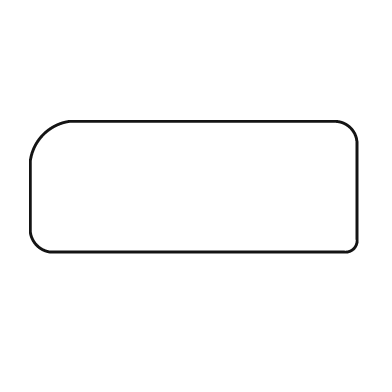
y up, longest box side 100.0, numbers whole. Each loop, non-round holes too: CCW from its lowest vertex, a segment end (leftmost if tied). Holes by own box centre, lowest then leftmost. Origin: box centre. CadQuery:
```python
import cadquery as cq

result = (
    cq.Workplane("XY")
    .moveTo(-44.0, -20.0)
    .lineTo(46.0, -20.0)
    .threePointArc((49.0, -19.0), (50.0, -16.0))
    .lineTo(50.0, 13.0)
    .threePointArc((48.0, 18.0), (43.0, 20.0))
    .lineTo(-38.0, 20.0)
    .threePointArc((-46.0, 16.0), (-50.0, 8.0))
    .lineTo(-50.0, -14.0)
    .threePointArc((-48.0, -18.0), (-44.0, -20.0))
    .close()
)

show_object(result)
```